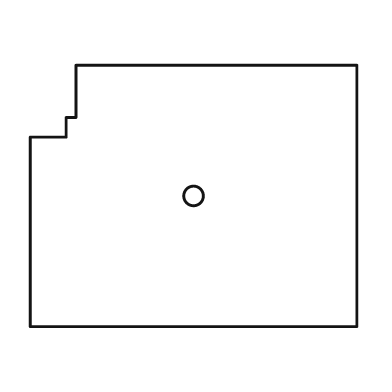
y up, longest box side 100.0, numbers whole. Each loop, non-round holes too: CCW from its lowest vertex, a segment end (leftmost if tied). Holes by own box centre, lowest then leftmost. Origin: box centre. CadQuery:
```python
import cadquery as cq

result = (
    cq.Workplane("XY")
    .moveTo(-50.0, -40.0)
    .lineTo(50.0, -40.0)
    .lineTo(50.0, 40.0)
    .lineTo(-36.0, 40.0)
    .lineTo(-36.0, 24.0)
    .lineTo(-39.0, 24.0)
    .lineTo(-39.0, 18.0)
    .lineTo(-50.0, 18.0)
    .close()
    .moveTo(0.0, 0.0)
    .circle(3.0)
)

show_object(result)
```